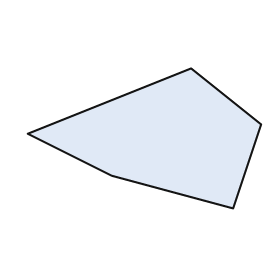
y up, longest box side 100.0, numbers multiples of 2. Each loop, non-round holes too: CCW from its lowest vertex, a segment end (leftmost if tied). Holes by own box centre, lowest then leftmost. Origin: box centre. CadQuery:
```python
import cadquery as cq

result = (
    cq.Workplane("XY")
    .moveTo(38.0, -30.0)
    .lineTo(50.0, 6.0)
    .lineTo(20.0, 30.0)
    .lineTo(-50.0, 2.0)
    .lineTo(-14.0, -16.0)
    .close()
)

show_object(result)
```